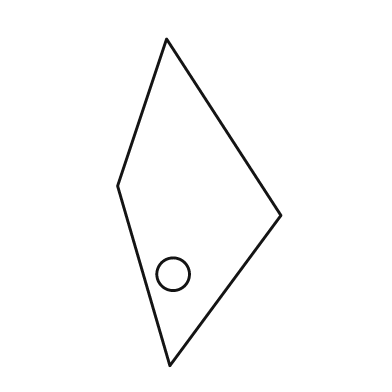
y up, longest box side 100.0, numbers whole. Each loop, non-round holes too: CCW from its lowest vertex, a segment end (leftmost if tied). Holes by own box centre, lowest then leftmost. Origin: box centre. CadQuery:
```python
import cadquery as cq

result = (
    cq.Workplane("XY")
    .moveTo(-9.0, -50.0)
    .lineTo(25.0, -4.0)
    .lineTo(-10.0, 50.0)
    .lineTo(-25.0, 5.0)
    .close()
    .moveTo(-8.0, -22.0)
    .circle(5.0)
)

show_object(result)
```